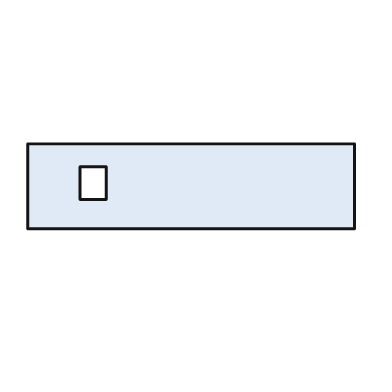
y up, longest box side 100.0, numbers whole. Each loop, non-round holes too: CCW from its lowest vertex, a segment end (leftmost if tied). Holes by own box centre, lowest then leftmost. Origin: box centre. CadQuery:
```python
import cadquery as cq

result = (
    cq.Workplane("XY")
    .moveTo(-50.0, -13.0)
    .lineTo(50.0, -13.0)
    .lineTo(50.0, 13.0)
    .lineTo(-50.0, 13.0)
    .close()
    .moveTo(-34.0, -4.0)
    .lineTo(-26.0, -4.0)
    .lineTo(-26.0, 6.0)
    .lineTo(-34.0, 6.0)
    .close()
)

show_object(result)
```